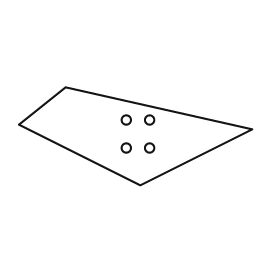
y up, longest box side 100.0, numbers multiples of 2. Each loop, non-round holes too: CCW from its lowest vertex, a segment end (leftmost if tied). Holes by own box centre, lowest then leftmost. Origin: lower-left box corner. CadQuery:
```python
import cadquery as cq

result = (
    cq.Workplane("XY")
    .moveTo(52.0, 0.0)
    .lineTo(100.0, 24.0)
    .lineTo(20.0, 42.0)
    .lineTo(0.0, 26.0)
    .close()
    .moveTo(46.0, 16.0)
    .circle(2.0)
    .moveTo(56.0, 16.0)
    .circle(2.0)
    .moveTo(46.0, 28.0)
    .circle(2.0)
    .moveTo(56.0, 28.0)
    .circle(2.0)
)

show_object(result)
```